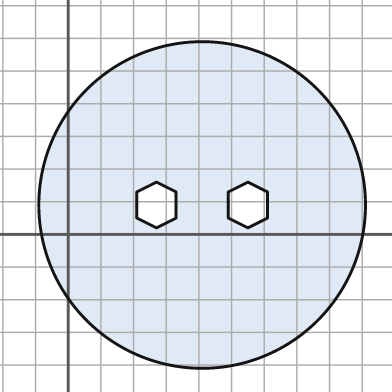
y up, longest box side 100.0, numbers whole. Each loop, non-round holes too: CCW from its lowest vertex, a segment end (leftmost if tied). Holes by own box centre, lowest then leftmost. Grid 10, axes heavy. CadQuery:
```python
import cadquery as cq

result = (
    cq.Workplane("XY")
    .moveTo(41.0, 9.0)
    .circle(50.0)
    .moveTo(27.0, 2.0)
    .lineTo(33.0, 5.0)
    .lineTo(33.0, 13.0)
    .lineTo(27.0, 16.0)
    .lineTo(21.0, 13.0)
    .lineTo(21.0, 5.0)
    .close()
    .moveTo(55.0, 2.0)
    .lineTo(61.0, 5.0)
    .lineTo(61.0, 13.0)
    .lineTo(55.0, 16.0)
    .lineTo(49.0, 13.0)
    .lineTo(49.0, 5.0)
    .close()
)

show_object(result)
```